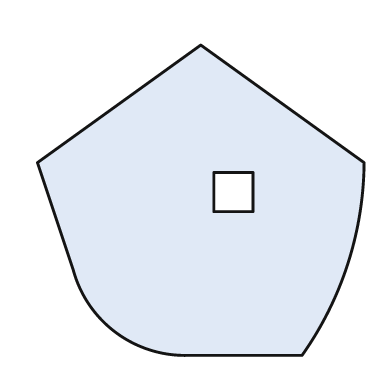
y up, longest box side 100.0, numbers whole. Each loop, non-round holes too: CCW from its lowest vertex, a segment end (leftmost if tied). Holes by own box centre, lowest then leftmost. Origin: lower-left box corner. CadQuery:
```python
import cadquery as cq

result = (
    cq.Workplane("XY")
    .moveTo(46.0, 0.0)
    .lineTo(81.0, 0.0)
    .threePointArc((95.0, 28.0), (100.0, 59.0))
    .lineTo(50.0, 95.0)
    .lineTo(0.0, 59.0)
    .lineTo(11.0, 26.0)
    .threePointArc((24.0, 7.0), (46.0, 0.0))
    .close()
    .moveTo(54.0, 44.0)
    .lineTo(66.0, 44.0)
    .lineTo(66.0, 56.0)
    .lineTo(54.0, 56.0)
    .close()
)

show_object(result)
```